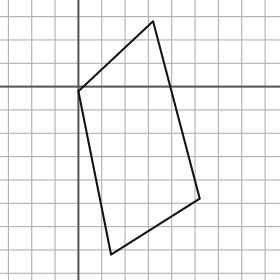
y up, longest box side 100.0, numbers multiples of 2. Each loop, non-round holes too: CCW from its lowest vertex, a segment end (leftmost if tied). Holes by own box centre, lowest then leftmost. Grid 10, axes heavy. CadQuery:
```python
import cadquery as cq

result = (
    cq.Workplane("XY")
    .moveTo(14.0, -72.0)
    .lineTo(52.0, -48.0)
    .lineTo(32.0, 28.0)
    .lineTo(0.0, -2.0)
    .close()
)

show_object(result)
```